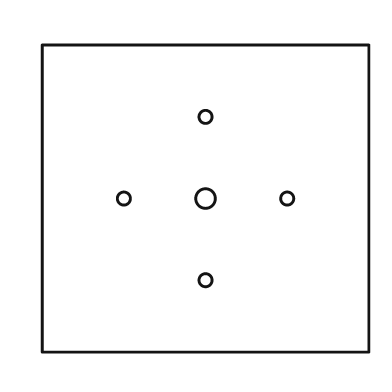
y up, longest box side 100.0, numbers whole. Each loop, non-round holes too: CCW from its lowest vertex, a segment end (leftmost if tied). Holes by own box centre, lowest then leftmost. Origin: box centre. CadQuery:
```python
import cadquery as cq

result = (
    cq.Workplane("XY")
    .moveTo(-50.0, -47.0)
    .lineTo(50.0, -47.0)
    .lineTo(50.0, 47.0)
    .lineTo(-50.0, 47.0)
    .close()
    .moveTo(0.0, -25.0)
    .circle(2.0)
    .moveTo(-25.0, 0.0)
    .circle(2.0)
    .moveTo(0.0, 0.0)
    .circle(3.0)
    .moveTo(25.0, 0.0)
    .circle(2.0)
    .moveTo(0.0, 25.0)
    .circle(2.0)
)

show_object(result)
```